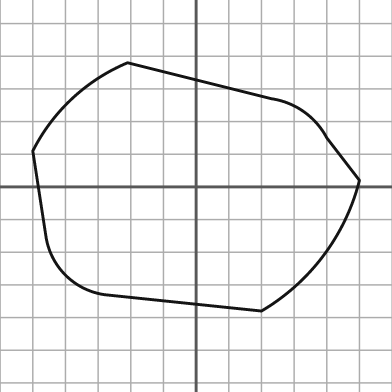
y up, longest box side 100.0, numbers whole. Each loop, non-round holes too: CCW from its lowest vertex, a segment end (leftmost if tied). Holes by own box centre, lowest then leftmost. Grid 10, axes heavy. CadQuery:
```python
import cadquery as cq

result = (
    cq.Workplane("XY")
    .moveTo(20.0, -38.0)
    .threePointArc((39.0, -21.0), (50.0, 2.0))
    .lineTo(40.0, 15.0)
    .threePointArc((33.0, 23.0), (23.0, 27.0))
    .lineTo(-21.0, 38.0)
    .threePointArc((-38.0, 27.0), (-50.0, 11.0))
    .lineTo(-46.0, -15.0)
    .threePointArc((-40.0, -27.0), (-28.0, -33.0))
    .close()
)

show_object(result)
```